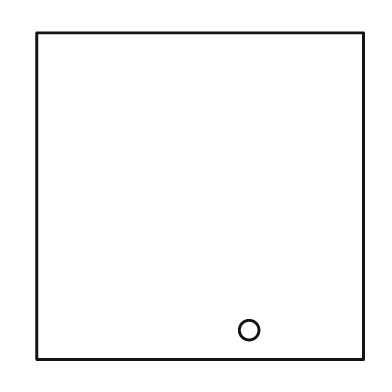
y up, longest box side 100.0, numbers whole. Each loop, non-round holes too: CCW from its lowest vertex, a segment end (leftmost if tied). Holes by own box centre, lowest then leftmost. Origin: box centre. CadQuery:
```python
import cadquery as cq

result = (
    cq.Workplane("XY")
    .moveTo(-50.0, -50.0)
    .lineTo(50.0, -50.0)
    .lineTo(50.0, 50.0)
    .lineTo(-50.0, 50.0)
    .close()
    .moveTo(15.0, -41.0)
    .circle(3.0)
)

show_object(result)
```